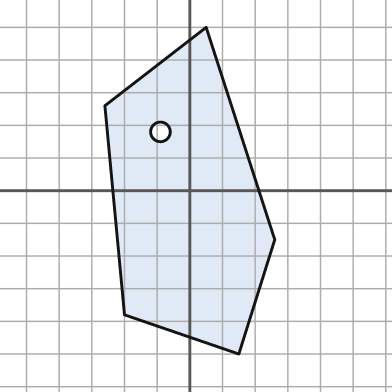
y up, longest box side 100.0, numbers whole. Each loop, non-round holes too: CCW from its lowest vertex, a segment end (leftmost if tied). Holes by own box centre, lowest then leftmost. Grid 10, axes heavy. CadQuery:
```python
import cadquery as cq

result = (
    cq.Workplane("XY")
    .moveTo(15.0, -50.0)
    .lineTo(26.0, -15.0)
    .lineTo(5.0, 50.0)
    .lineTo(-26.0, 26.0)
    .lineTo(-20.0, -38.0)
    .close()
    .moveTo(-9.0, 18.0)
    .circle(3.0)
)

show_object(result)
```